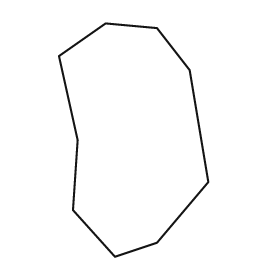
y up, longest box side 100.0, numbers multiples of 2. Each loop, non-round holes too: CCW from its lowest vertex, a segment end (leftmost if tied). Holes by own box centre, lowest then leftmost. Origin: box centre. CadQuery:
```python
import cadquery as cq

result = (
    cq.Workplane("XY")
    .moveTo(-8.0, -50.0)
    .lineTo(10.0, -44.0)
    .lineTo(32.0, -18.0)
    .lineTo(24.0, 30.0)
    .lineTo(10.0, 48.0)
    .lineTo(-12.0, 50.0)
    .lineTo(-32.0, 36.0)
    .lineTo(-24.0, 0.0)
    .lineTo(-26.0, -30.0)
    .close()
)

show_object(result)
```